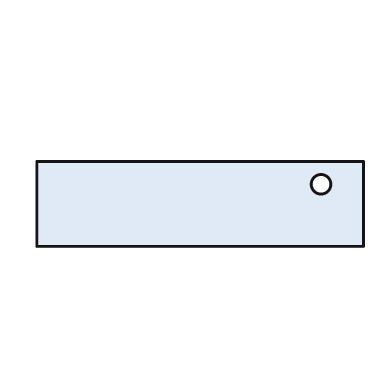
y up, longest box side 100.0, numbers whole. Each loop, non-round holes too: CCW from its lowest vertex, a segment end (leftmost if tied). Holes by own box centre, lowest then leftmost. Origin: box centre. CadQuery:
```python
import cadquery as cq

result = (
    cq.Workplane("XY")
    .moveTo(-50.0, -13.0)
    .lineTo(50.0, -13.0)
    .lineTo(50.0, 13.0)
    .lineTo(-50.0, 13.0)
    .close()
    .moveTo(37.0, 6.0)
    .circle(3.0)
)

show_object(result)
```